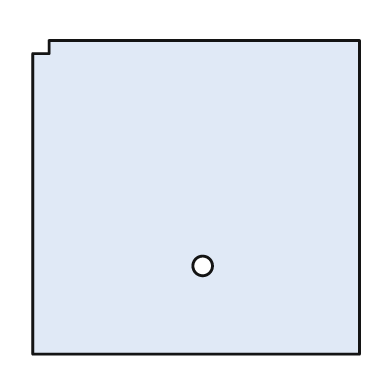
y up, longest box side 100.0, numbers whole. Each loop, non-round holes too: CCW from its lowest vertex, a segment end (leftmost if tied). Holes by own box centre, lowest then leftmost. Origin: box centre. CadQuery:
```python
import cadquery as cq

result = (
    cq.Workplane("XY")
    .moveTo(-50.0, -48.0)
    .lineTo(50.0, -48.0)
    .lineTo(50.0, 48.0)
    .lineTo(-45.0, 48.0)
    .lineTo(-45.0, 44.0)
    .lineTo(-50.0, 44.0)
    .close()
    .moveTo(2.0, -21.0)
    .circle(3.0)
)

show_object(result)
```